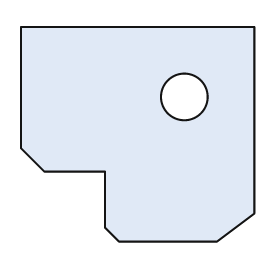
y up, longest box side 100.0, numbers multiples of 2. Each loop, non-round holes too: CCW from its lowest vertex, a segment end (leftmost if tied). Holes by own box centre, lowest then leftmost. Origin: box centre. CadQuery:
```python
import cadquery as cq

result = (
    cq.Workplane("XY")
    .moveTo(-8.0, -46.0)
    .lineTo(34.0, -46.0)
    .lineTo(50.0, -34.0)
    .lineTo(50.0, 46.0)
    .lineTo(-50.0, 46.0)
    .lineTo(-50.0, -6.0)
    .lineTo(-40.0, -16.0)
    .lineTo(-14.0, -16.0)
    .lineTo(-14.0, -40.0)
    .close()
    .moveTo(20.0, 16.0)
    .circle(10.0)
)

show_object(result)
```